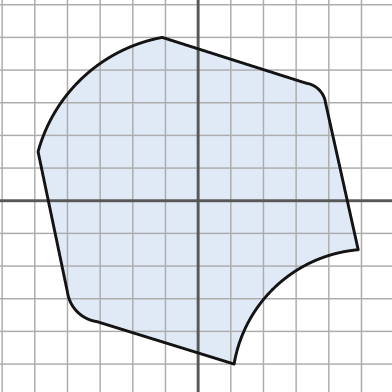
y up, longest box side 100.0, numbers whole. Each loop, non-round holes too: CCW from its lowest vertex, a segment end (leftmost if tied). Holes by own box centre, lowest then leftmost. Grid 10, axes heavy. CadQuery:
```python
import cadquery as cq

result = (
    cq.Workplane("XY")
    .moveTo(11.0, -50.0)
    .threePointArc((24.0, -26.0), (49.0, -15.0))
    .lineTo(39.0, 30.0)
    .threePointArc((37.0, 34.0), (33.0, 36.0))
    .lineTo(-11.0, 50.0)
    .threePointArc((-35.0, 38.0), (-49.0, 15.0))
    .lineTo(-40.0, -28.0)
    .threePointArc((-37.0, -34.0), (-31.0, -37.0))
    .close()
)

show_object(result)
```